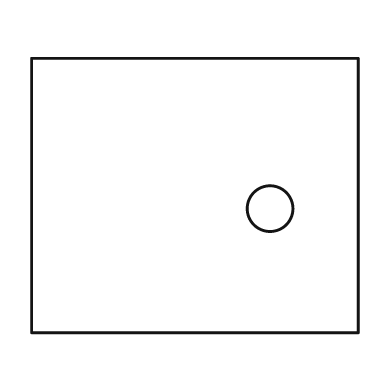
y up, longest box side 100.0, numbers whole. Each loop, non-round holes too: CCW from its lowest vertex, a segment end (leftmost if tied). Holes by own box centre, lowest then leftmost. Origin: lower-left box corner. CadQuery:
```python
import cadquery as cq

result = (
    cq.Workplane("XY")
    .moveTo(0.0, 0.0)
    .lineTo(100.0, 0.0)
    .lineTo(100.0, 84.0)
    .lineTo(0.0, 84.0)
    .close()
    .moveTo(73.0, 38.0)
    .circle(7.0)
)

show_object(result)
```